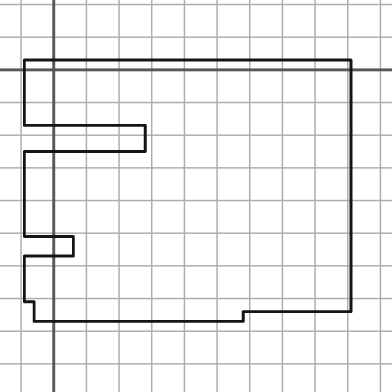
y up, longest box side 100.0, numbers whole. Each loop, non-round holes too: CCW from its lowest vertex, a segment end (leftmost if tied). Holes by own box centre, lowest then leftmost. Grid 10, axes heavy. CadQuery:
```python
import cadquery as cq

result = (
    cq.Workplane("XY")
    .moveTo(-6.0, -77.0)
    .lineTo(58.0, -77.0)
    .lineTo(58.0, -74.0)
    .lineTo(91.0, -74.0)
    .lineTo(91.0, 3.0)
    .lineTo(-9.0, 3.0)
    .lineTo(-9.0, -17.0)
    .lineTo(28.0, -17.0)
    .lineTo(28.0, -25.0)
    .lineTo(-9.0, -25.0)
    .lineTo(-9.0, -51.0)
    .lineTo(6.0, -51.0)
    .lineTo(6.0, -57.0)
    .lineTo(-9.0, -57.0)
    .lineTo(-9.0, -71.0)
    .lineTo(-6.0, -71.0)
    .close()
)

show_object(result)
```